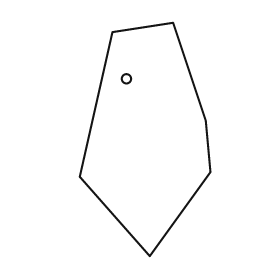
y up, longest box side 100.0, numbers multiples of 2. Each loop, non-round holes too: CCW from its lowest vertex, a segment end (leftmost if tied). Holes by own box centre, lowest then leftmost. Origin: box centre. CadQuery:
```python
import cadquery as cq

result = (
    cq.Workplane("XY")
    .moveTo(2.0, -50.0)
    .lineTo(28.0, -14.0)
    .lineTo(26.0, 8.0)
    .lineTo(12.0, 50.0)
    .lineTo(-14.0, 46.0)
    .lineTo(-28.0, -16.0)
    .close()
    .moveTo(-8.0, 26.0)
    .circle(2.0)
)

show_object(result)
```